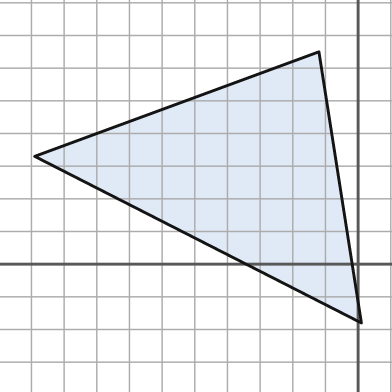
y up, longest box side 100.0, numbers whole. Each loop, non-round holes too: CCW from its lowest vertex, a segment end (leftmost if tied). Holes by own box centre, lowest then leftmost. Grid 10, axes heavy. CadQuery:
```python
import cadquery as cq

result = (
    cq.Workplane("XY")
    .moveTo(1.0, -18.0)
    .lineTo(-12.0, 65.0)
    .lineTo(-99.0, 33.0)
    .close()
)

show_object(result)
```